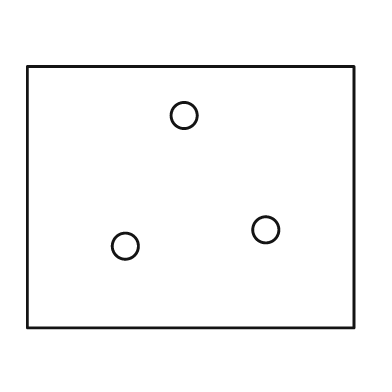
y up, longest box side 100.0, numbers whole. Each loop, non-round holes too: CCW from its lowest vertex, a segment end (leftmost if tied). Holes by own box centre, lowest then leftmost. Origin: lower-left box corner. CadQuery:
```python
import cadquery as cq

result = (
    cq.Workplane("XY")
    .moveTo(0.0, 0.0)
    .lineTo(100.0, 0.0)
    .lineTo(100.0, 80.0)
    .lineTo(0.0, 80.0)
    .close()
    .moveTo(30.0, 25.0)
    .circle(4.0)
    .moveTo(73.0, 30.0)
    .circle(4.0)
    .moveTo(48.0, 65.0)
    .circle(4.0)
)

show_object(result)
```